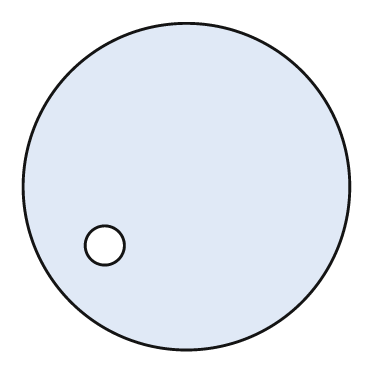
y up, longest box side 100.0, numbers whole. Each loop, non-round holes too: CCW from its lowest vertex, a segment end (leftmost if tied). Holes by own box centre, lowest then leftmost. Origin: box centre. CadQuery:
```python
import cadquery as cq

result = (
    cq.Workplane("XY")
    .moveTo(0.0, 0.0)
    .circle(50.0)
    .moveTo(-25.0, -18.0)
    .circle(6.0)
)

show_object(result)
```